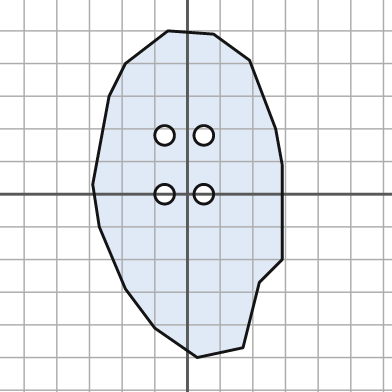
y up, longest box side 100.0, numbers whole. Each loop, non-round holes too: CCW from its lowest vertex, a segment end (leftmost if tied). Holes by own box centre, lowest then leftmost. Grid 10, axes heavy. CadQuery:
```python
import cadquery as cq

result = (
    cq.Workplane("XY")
    .moveTo(3.0, -50.0)
    .lineTo(17.0, -47.0)
    .lineTo(22.0, -27.0)
    .lineTo(29.0, -20.0)
    .lineTo(29.0, 9.0)
    .lineTo(27.0, 20.0)
    .lineTo(19.0, 41.0)
    .lineTo(8.0, 49.0)
    .lineTo(-6.0, 50.0)
    .lineTo(-19.0, 40.0)
    .lineTo(-24.0, 30.0)
    .lineTo(-29.0, 3.0)
    .lineTo(-27.0, -10.0)
    .lineTo(-19.0, -29.0)
    .lineTo(-10.0, -41.0)
    .close()
    .moveTo(-7.0, 0.0)
    .circle(3.0)
    .moveTo(5.0, 0.0)
    .circle(3.0)
    .moveTo(-7.0, 18.0)
    .circle(3.0)
    .moveTo(5.0, 18.0)
    .circle(3.0)
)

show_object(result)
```